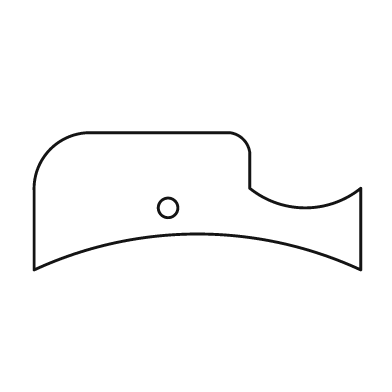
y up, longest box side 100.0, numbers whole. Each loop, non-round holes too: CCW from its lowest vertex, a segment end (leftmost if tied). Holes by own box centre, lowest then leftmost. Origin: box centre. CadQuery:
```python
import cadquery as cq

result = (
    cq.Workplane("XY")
    .moveTo(-50.0, -21.0)
    .threePointArc((0.0, -10.0), (50.0, -21.0))
    .lineTo(50.0, 4.0)
    .threePointArc((33.0, -2.0), (16.0, 4.0))
    .lineTo(16.0, 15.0)
    .threePointArc((14.0, 19.0), (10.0, 21.0))
    .lineTo(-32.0, 21.0)
    .threePointArc((-45.0, 16.0), (-50.0, 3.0))
    .close()
    .moveTo(-9.0, -2.0)
    .circle(3.0)
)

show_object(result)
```